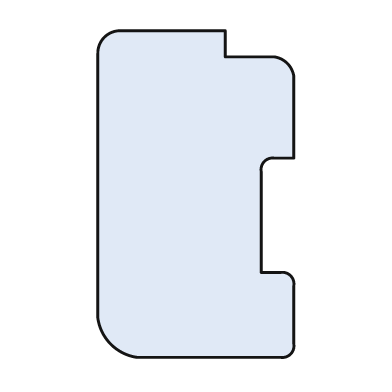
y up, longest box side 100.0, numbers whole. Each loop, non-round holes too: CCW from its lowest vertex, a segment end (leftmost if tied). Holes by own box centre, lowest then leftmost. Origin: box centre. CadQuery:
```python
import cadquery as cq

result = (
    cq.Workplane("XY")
    .moveTo(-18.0, -50.0)
    .lineTo(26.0, -50.0)
    .threePointArc((29.0, -49.0), (30.0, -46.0))
    .lineTo(30.0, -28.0)
    .threePointArc((29.0, -25.0), (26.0, -24.0))
    .lineTo(20.0, -24.0)
    .lineTo(20.0, 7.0)
    .threePointArc((21.0, 10.0), (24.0, 11.0))
    .lineTo(30.0, 11.0)
    .lineTo(30.0, 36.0)
    .threePointArc((28.0, 40.0), (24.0, 42.0))
    .lineTo(9.0, 42.0)
    .lineTo(9.0, 50.0)
    .lineTo(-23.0, 50.0)
    .threePointArc((-28.0, 48.0), (-30.0, 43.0))
    .lineTo(-30.0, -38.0)
    .threePointArc((-26.0, -46.0), (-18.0, -50.0))
    .close()
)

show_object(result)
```